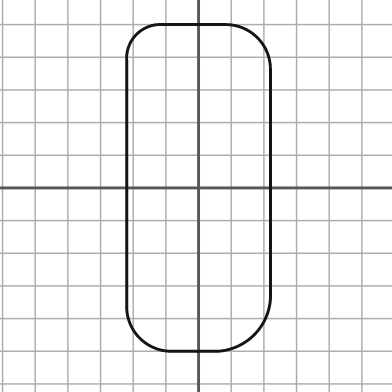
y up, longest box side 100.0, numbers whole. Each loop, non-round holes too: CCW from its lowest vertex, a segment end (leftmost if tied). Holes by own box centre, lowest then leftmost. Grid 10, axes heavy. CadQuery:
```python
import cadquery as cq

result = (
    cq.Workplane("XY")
    .moveTo(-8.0, -50.0)
    .lineTo(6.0, -50.0)
    .threePointArc((17.0, -45.0), (22.0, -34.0))
    .lineTo(22.0, 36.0)
    .threePointArc((18.0, 46.0), (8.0, 50.0))
    .lineTo(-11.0, 50.0)
    .threePointArc((-19.0, 47.0), (-22.0, 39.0))
    .lineTo(-22.0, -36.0)
    .threePointArc((-18.0, -46.0), (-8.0, -50.0))
    .close()
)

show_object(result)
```